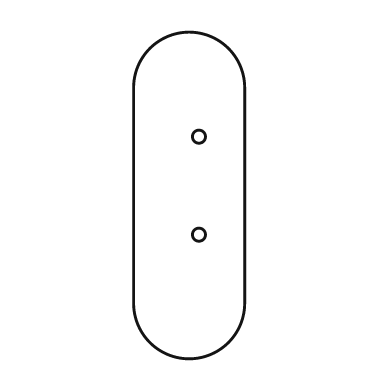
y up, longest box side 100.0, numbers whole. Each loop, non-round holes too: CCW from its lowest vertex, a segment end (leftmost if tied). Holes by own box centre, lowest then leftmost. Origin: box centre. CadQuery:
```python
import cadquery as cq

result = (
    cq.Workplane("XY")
    .moveTo(-17.0, -33.0)
    .threePointArc((0.0, -50.0), (17.0, -33.0))
    .lineTo(17.0, 33.0)
    .threePointArc((0.0, 50.0), (-17.0, 33.0))
    .close()
    .moveTo(3.0, -12.0)
    .circle(2.0)
    .moveTo(3.0, 18.0)
    .circle(2.0)
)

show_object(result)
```